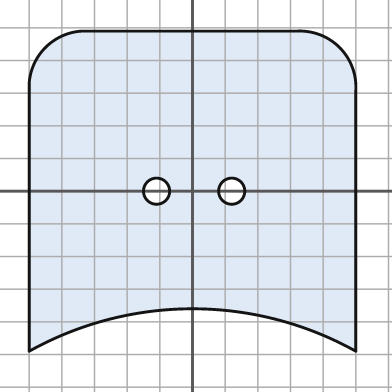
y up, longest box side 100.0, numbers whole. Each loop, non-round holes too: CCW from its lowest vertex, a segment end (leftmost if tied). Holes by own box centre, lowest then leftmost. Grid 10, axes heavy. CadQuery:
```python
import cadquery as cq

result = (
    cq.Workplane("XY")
    .moveTo(-50.0, -49.0)
    .threePointArc((0.0, -36.0), (50.0, -49.0))
    .lineTo(50.0, 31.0)
    .threePointArc((45.0, 44.0), (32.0, 49.0))
    .lineTo(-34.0, 49.0)
    .threePointArc((-45.0, 44.0), (-50.0, 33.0))
    .close()
    .moveTo(-11.0, 0.0)
    .circle(4.0)
    .moveTo(12.0, 0.0)
    .circle(4.0)
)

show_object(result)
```